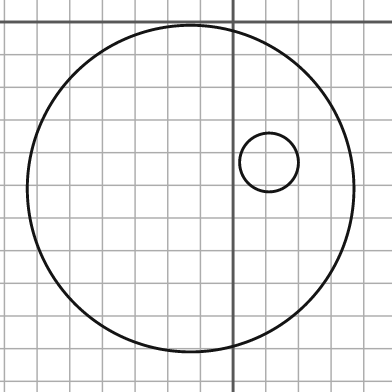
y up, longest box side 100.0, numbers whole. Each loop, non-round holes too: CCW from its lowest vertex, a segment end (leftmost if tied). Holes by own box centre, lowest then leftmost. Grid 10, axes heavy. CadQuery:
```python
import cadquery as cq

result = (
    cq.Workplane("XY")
    .moveTo(-13.0, -51.0)
    .circle(50.0)
    .moveTo(11.0, -43.0)
    .circle(9.0)
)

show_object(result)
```